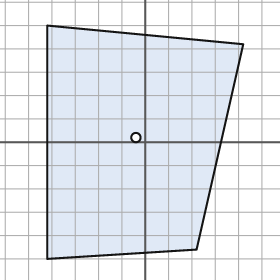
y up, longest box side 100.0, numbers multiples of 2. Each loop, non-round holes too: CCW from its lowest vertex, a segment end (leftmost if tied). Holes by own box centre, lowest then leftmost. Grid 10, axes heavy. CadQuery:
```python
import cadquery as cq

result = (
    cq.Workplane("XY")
    .moveTo(-42.0, -50.0)
    .lineTo(22.0, -46.0)
    .lineTo(42.0, 42.0)
    .lineTo(-42.0, 50.0)
    .close()
    .moveTo(-4.0, 2.0)
    .circle(2.0)
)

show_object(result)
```